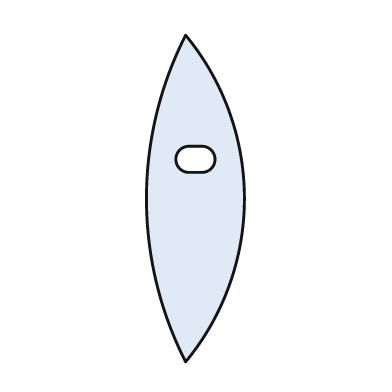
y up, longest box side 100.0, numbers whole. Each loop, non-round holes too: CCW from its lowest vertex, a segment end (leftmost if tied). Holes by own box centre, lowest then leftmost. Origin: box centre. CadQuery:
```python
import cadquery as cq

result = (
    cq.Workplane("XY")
    .moveTo(-3.0, -50.0)
    .threePointArc((15.0, 0.0), (-3.0, 50.0))
    .threePointArc((-15.0, 0.0), (-3.0, -50.0))
    .close()
    .moveTo(-2.0, 8.0)
    .lineTo(2.0, 8.0)
    .threePointArc((6.0, 12.0), (2.0, 16.0))
    .lineTo(-2.0, 16.0)
    .threePointArc((-6.0, 12.0), (-2.0, 8.0))
    .close()
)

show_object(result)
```